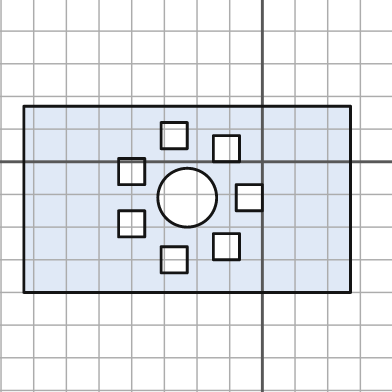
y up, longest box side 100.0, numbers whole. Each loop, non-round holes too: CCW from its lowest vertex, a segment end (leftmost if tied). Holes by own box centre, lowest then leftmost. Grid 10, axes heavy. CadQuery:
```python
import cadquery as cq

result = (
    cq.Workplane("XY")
    .moveTo(-73.0, -40.0)
    .lineTo(27.0, -40.0)
    .lineTo(27.0, 17.0)
    .lineTo(-73.0, 17.0)
    .close()
    .moveTo(-31.0, -34.0)
    .lineTo(-23.0, -34.0)
    .lineTo(-23.0, -26.0)
    .lineTo(-31.0, -26.0)
    .close()
    .moveTo(-15.0, -30.0)
    .lineTo(-7.0, -30.0)
    .lineTo(-7.0, -22.0)
    .lineTo(-15.0, -22.0)
    .close()
    .moveTo(-44.0, -23.0)
    .lineTo(-36.0, -23.0)
    .lineTo(-36.0, -15.0)
    .lineTo(-44.0, -15.0)
    .close()
    .moveTo(-23.0, -11.0)
    .circle(9.0)
    .moveTo(-8.0, -15.0)
    .lineTo(0.0, -15.0)
    .lineTo(0.0, -7.0)
    .lineTo(-8.0, -7.0)
    .close()
    .moveTo(-44.0, -7.0)
    .lineTo(-36.0, -7.0)
    .lineTo(-36.0, 1.0)
    .lineTo(-44.0, 1.0)
    .close()
    .moveTo(-15.0, 0.0)
    .lineTo(-7.0, 0.0)
    .lineTo(-7.0, 8.0)
    .lineTo(-15.0, 8.0)
    .close()
    .moveTo(-31.0, 4.0)
    .lineTo(-23.0, 4.0)
    .lineTo(-23.0, 12.0)
    .lineTo(-31.0, 12.0)
    .close()
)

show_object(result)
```